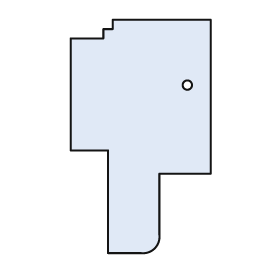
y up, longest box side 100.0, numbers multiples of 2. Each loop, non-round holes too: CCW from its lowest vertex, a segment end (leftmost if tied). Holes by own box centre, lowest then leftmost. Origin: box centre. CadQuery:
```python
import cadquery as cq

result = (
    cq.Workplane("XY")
    .moveTo(-14.0, -50.0)
    .lineTo(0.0, -50.0)
    .threePointArc((6.0, -48.0), (8.0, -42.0))
    .lineTo(8.0, -16.0)
    .lineTo(30.0, -16.0)
    .lineTo(30.0, 50.0)
    .lineTo(-12.0, 50.0)
    .lineTo(-12.0, 46.0)
    .lineTo(-16.0, 46.0)
    .lineTo(-16.0, 42.0)
    .lineTo(-30.0, 42.0)
    .lineTo(-30.0, -6.0)
    .lineTo(-14.0, -6.0)
    .close()
    .moveTo(20.0, 22.0)
    .circle(2.0)
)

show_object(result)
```